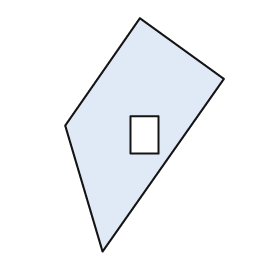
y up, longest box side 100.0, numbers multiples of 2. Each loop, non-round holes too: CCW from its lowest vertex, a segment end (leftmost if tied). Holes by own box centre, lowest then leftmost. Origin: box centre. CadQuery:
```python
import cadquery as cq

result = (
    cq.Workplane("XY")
    .moveTo(-18.0, -50.0)
    .lineTo(34.0, 24.0)
    .lineTo(-2.0, 50.0)
    .lineTo(-34.0, 4.0)
    .close()
    .moveTo(-6.0, -8.0)
    .lineTo(6.0, -8.0)
    .lineTo(6.0, 8.0)
    .lineTo(-6.0, 8.0)
    .close()
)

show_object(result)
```